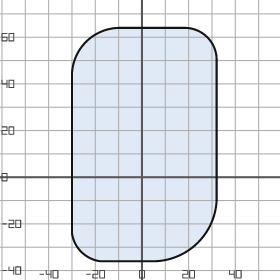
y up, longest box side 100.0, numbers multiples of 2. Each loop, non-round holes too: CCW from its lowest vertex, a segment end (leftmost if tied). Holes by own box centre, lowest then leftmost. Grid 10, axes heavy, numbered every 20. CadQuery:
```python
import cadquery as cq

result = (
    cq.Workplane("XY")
    .moveTo(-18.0, -36.0)
    .lineTo(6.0, -36.0)
    .threePointArc((24.0, -28.0), (32.0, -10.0))
    .lineTo(32.0, 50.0)
    .threePointArc((28.0, 60.0), (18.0, 64.0))
    .lineTo(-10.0, 64.0)
    .threePointArc((-24.0, 58.0), (-30.0, 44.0))
    .lineTo(-30.0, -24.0)
    .threePointArc((-26.0, -32.0), (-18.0, -36.0))
    .close()
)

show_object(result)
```